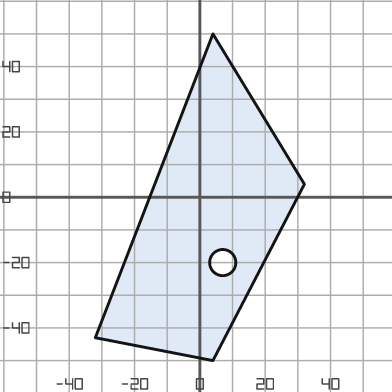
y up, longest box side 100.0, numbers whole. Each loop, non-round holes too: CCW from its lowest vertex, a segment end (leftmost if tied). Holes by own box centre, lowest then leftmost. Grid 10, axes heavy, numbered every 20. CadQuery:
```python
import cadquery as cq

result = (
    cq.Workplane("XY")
    .moveTo(4.0, -50.0)
    .lineTo(32.0, 4.0)
    .lineTo(4.0, 50.0)
    .lineTo(-32.0, -43.0)
    .close()
    .moveTo(7.0, -20.0)
    .circle(4.0)
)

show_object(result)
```